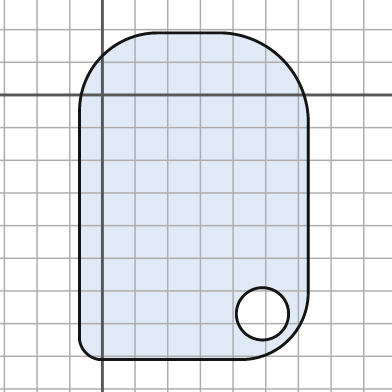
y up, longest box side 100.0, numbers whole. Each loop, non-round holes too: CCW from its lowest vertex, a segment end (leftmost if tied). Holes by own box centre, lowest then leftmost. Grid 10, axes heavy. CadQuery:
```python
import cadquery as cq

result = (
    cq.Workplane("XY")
    .moveTo(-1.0, -81.0)
    .lineTo(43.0, -81.0)
    .threePointArc((57.0, -75.0), (63.0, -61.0))
    .lineTo(63.0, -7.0)
    .threePointArc((55.0, 11.0), (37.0, 19.0))
    .lineTo(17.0, 19.0)
    .threePointArc((0.0, 12.0), (-7.0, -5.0))
    .lineTo(-7.0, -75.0)
    .threePointArc((-5.0, -79.0), (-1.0, -81.0))
    .close()
    .moveTo(49.0, -67.0)
    .circle(8.0)
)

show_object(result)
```